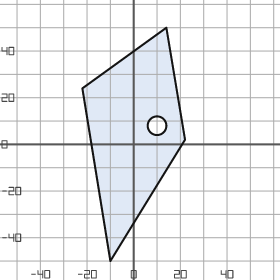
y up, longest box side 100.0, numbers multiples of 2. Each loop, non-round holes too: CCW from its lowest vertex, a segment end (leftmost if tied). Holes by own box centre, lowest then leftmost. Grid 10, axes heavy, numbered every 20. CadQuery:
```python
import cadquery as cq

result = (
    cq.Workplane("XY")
    .moveTo(-10.0, -50.0)
    .lineTo(22.0, 2.0)
    .lineTo(14.0, 50.0)
    .lineTo(-22.0, 24.0)
    .close()
    .moveTo(10.0, 8.0)
    .circle(4.0)
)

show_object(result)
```